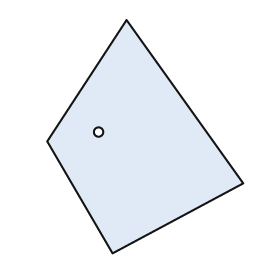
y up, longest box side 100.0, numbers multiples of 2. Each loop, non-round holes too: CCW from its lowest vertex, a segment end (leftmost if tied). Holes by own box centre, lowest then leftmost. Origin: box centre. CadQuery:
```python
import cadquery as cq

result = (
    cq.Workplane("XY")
    .moveTo(-14.0, -50.0)
    .lineTo(42.0, -20.0)
    .lineTo(-8.0, 50.0)
    .lineTo(-42.0, -2.0)
    .close()
    .moveTo(-20.0, 2.0)
    .circle(2.0)
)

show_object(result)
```